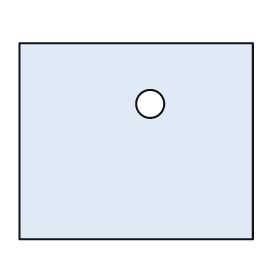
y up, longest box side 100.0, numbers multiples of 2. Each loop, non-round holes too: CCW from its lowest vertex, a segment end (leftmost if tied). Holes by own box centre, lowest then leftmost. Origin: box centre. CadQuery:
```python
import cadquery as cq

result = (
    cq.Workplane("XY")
    .moveTo(-50.0, -42.0)
    .lineTo(50.0, -42.0)
    .lineTo(50.0, 42.0)
    .lineTo(-50.0, 42.0)
    .close()
    .moveTo(6.0, 16.0)
    .circle(6.0)
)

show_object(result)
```